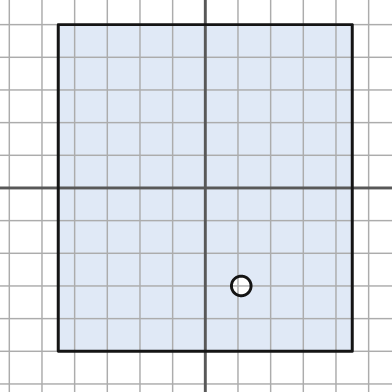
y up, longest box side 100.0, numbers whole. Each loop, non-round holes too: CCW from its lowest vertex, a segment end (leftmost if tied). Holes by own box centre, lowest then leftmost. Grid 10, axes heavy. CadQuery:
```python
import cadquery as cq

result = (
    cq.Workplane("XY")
    .moveTo(-45.0, -50.0)
    .lineTo(45.0, -50.0)
    .lineTo(45.0, 50.0)
    .lineTo(-45.0, 50.0)
    .close()
    .moveTo(11.0, -30.0)
    .circle(3.0)
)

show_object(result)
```